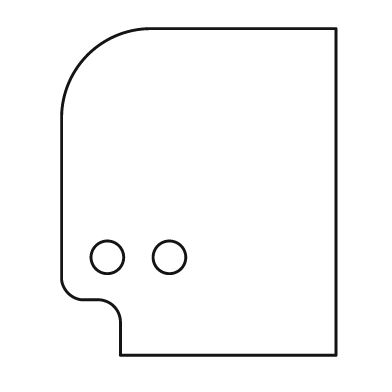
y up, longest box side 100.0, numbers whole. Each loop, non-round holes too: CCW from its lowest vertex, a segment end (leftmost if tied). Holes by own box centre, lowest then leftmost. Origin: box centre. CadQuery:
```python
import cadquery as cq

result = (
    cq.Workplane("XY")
    .moveTo(-24.0, -50.0)
    .lineTo(42.0, -50.0)
    .lineTo(42.0, 50.0)
    .lineTo(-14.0, 50.0)
    .threePointArc((-34.0, 42.0), (-42.0, 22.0))
    .lineTo(-42.0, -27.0)
    .threePointArc((-40.0, -31.0), (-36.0, -33.0))
    .lineTo(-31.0, -33.0)
    .threePointArc((-26.0, -35.0), (-24.0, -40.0))
    .close()
    .moveTo(-28.0, -20.0)
    .circle(5.0)
    .moveTo(-9.0, -20.0)
    .circle(5.0)
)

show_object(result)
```